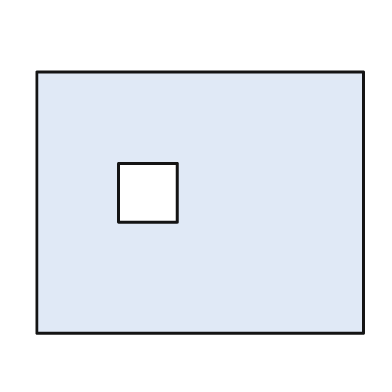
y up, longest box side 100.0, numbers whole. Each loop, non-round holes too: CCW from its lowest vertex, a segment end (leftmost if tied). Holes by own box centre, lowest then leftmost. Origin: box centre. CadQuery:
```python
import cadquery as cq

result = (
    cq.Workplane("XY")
    .moveTo(-50.0, -40.0)
    .lineTo(50.0, -40.0)
    .lineTo(50.0, 40.0)
    .lineTo(-50.0, 40.0)
    .close()
    .moveTo(-25.0, -6.0)
    .lineTo(-7.0, -6.0)
    .lineTo(-7.0, 12.0)
    .lineTo(-25.0, 12.0)
    .close()
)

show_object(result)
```